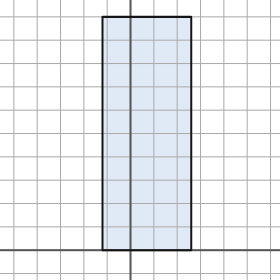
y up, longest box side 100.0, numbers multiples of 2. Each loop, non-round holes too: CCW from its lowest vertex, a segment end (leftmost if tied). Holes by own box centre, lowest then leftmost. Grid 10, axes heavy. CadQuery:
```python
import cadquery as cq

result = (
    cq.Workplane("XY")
    .moveTo(-12.0, 0.0)
    .lineTo(26.0, 0.0)
    .lineTo(26.0, 100.0)
    .lineTo(-12.0, 100.0)
    .close()
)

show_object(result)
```